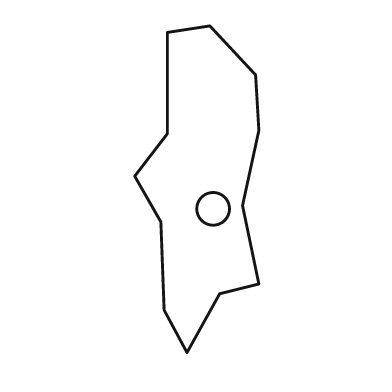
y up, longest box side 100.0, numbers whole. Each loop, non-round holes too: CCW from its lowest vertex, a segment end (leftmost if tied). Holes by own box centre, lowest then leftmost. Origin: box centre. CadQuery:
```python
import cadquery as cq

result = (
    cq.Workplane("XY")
    .moveTo(-3.0, -50.0)
    .lineTo(7.0, -32.0)
    .lineTo(19.0, -29.0)
    .lineTo(14.0, -5.0)
    .lineTo(19.0, 18.0)
    .lineTo(18.0, 35.0)
    .lineTo(4.0, 50.0)
    .lineTo(-9.0, 48.0)
    .lineTo(-9.0, 17.0)
    .lineTo(-19.0, 4.0)
    .lineTo(-11.0, -10.0)
    .lineTo(-10.0, -37.0)
    .close()
    .moveTo(5.0, -6.0)
    .circle(5.0)
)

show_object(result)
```